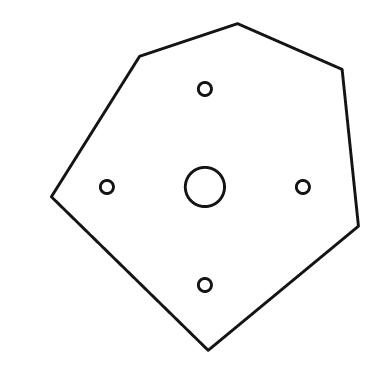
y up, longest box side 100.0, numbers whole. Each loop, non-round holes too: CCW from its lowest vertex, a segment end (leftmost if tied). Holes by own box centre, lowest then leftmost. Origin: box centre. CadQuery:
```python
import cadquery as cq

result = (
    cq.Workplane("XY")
    .moveTo(1.0, -50.0)
    .lineTo(47.0, -12.0)
    .lineTo(42.0, 36.0)
    .lineTo(10.0, 50.0)
    .lineTo(-20.0, 40.0)
    .lineTo(-47.0, -3.0)
    .close()
    .moveTo(0.0, -30.0)
    .circle(2.0)
    .moveTo(-30.0, 0.0)
    .circle(2.0)
    .moveTo(0.0, 0.0)
    .circle(6.0)
    .moveTo(30.0, 0.0)
    .circle(2.0)
    .moveTo(0.0, 30.0)
    .circle(2.0)
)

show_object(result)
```